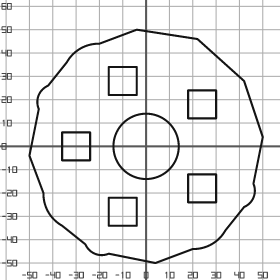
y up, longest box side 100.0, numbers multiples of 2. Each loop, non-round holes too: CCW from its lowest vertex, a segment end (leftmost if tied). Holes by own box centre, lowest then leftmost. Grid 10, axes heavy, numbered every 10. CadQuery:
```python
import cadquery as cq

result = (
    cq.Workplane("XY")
    .moveTo(4.0, -50.0)
    .lineTo(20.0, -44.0)
    .threePointArc((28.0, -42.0), (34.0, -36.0))
    .lineTo(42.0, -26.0)
    .threePointArc((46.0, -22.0), (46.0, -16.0))
    .lineTo(50.0, 4.0)
    .lineTo(42.0, 28.0)
    .lineTo(22.0, 46.0)
    .lineTo(-4.0, 50.0)
    .lineTo(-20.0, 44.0)
    .threePointArc((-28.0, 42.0), (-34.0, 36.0))
    .lineTo(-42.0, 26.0)
    .threePointArc((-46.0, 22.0), (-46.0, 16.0))
    .lineTo(-50.0, -4.0)
    .lineTo(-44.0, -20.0)
    .threePointArc((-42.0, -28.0), (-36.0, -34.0))
    .lineTo(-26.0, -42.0)
    .threePointArc((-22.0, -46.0), (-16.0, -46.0))
    .close()
    .moveTo(-16.0, -34.0)
    .lineTo(-4.0, -34.0)
    .lineTo(-4.0, -22.0)
    .lineTo(-16.0, -22.0)
    .close()
    .moveTo(18.0, -24.0)
    .lineTo(30.0, -24.0)
    .lineTo(30.0, -12.0)
    .lineTo(18.0, -12.0)
    .close()
    .moveTo(-36.0, -6.0)
    .lineTo(-24.0, -6.0)
    .lineTo(-24.0, 6.0)
    .lineTo(-36.0, 6.0)
    .close()
    .moveTo(0.0, 0.0)
    .circle(14.0)
    .moveTo(18.0, 12.0)
    .lineTo(30.0, 12.0)
    .lineTo(30.0, 24.0)
    .lineTo(18.0, 24.0)
    .close()
    .moveTo(-16.0, 22.0)
    .lineTo(-4.0, 22.0)
    .lineTo(-4.0, 34.0)
    .lineTo(-16.0, 34.0)
    .close()
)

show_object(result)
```